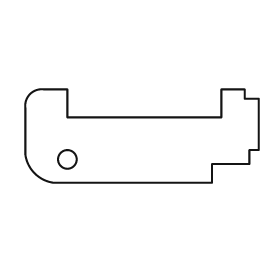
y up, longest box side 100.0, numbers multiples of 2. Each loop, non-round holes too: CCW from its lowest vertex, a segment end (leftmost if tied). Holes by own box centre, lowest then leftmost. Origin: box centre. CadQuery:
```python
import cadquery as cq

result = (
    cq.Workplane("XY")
    .moveTo(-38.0, -20.0)
    .lineTo(30.0, -20.0)
    .lineTo(30.0, -12.0)
    .lineTo(46.0, -12.0)
    .lineTo(46.0, -6.0)
    .lineTo(50.0, -6.0)
    .lineTo(50.0, 16.0)
    .lineTo(44.0, 16.0)
    .lineTo(44.0, 20.0)
    .lineTo(34.0, 20.0)
    .lineTo(34.0, 8.0)
    .lineTo(-32.0, 8.0)
    .lineTo(-32.0, 20.0)
    .lineTo(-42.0, 20.0)
    .threePointArc((-48.0, 18.0), (-50.0, 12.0))
    .lineTo(-50.0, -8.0)
    .threePointArc((-46.0, -16.0), (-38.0, -20.0))
    .close()
    .moveTo(-32.0, -10.0)
    .circle(4.0)
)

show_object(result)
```